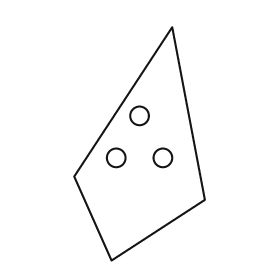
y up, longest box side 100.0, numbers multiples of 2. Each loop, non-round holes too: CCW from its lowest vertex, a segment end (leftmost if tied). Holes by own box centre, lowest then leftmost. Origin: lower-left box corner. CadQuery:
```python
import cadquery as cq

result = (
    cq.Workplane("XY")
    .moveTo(16.0, 0.0)
    .lineTo(56.0, 26.0)
    .lineTo(42.0, 100.0)
    .lineTo(0.0, 36.0)
    .close()
    .moveTo(18.0, 44.0)
    .circle(4.0)
    .moveTo(38.0, 44.0)
    .circle(4.0)
    .moveTo(28.0, 62.0)
    .circle(4.0)
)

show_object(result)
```